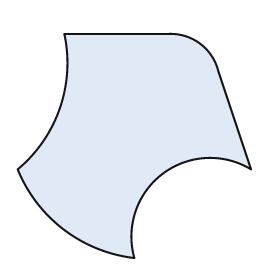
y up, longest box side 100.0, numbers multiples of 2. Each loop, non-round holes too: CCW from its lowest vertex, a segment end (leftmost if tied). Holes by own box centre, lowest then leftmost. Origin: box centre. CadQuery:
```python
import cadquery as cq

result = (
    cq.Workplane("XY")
    .moveTo(0.0, -48.0)
    .threePointArc((12.0, -12.0), (50.0, -10.0))
    .lineTo(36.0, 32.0)
    .threePointArc((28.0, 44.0), (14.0, 48.0))
    .lineTo(-30.0, 48.0)
    .threePointArc((-32.0, 16.0), (-50.0, -10.0))
    .threePointArc((-30.0, -36.0), (0.0, -48.0))
    .close()
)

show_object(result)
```